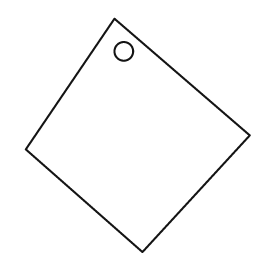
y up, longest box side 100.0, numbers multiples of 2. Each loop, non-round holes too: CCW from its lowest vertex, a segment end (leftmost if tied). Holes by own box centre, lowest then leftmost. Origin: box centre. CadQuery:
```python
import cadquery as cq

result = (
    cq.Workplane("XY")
    .moveTo(2.0, -50.0)
    .lineTo(48.0, 0.0)
    .lineTo(-10.0, 50.0)
    .lineTo(-48.0, -6.0)
    .close()
    .moveTo(-6.0, 36.0)
    .circle(4.0)
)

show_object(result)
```